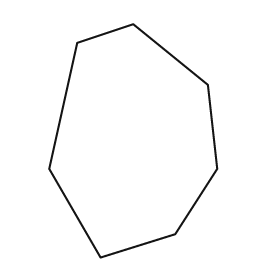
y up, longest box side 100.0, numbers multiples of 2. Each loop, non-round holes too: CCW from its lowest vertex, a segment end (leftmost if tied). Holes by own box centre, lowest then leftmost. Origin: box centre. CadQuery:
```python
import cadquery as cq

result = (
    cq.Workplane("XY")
    .moveTo(-14.0, -50.0)
    .lineTo(18.0, -40.0)
    .lineTo(36.0, -12.0)
    .lineTo(32.0, 24.0)
    .lineTo(0.0, 50.0)
    .lineTo(-24.0, 42.0)
    .lineTo(-36.0, -12.0)
    .close()
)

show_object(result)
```